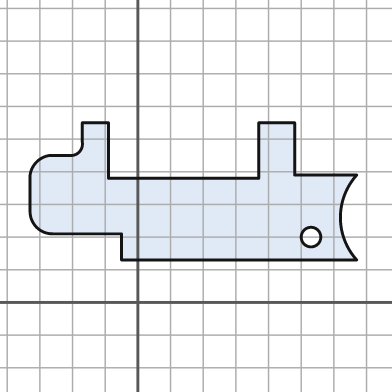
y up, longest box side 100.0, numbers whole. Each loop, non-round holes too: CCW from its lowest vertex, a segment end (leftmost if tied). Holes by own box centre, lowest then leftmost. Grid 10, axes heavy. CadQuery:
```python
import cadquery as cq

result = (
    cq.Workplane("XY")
    .moveTo(-5.0, 13.0)
    .lineTo(67.0, 13.0)
    .threePointArc((62.0, 26.0), (67.0, 39.0))
    .lineTo(48.0, 39.0)
    .lineTo(48.0, 55.0)
    .lineTo(37.0, 55.0)
    .lineTo(37.0, 38.0)
    .lineTo(-9.0, 38.0)
    .lineTo(-9.0, 55.0)
    .lineTo(-17.0, 55.0)
    .lineTo(-17.0, 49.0)
    .threePointArc((-18.0, 46.0), (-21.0, 45.0))
    .lineTo(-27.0, 45.0)
    .threePointArc((-31.0, 43.0), (-33.0, 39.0))
    .lineTo(-33.0, 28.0)
    .threePointArc((-31.0, 23.0), (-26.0, 21.0))
    .lineTo(-5.0, 21.0)
    .close()
    .moveTo(53.0, 20.0)
    .circle(3.0)
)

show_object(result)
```